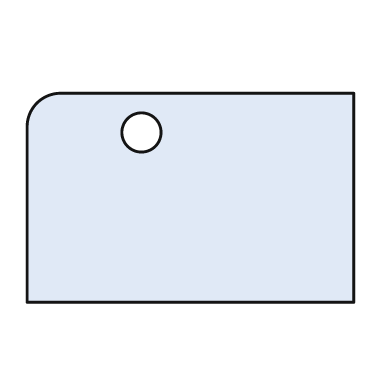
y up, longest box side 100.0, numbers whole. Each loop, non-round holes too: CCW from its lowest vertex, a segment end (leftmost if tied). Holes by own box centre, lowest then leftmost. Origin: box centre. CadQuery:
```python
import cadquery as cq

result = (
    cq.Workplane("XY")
    .moveTo(-50.0, -32.0)
    .lineTo(50.0, -32.0)
    .lineTo(50.0, 32.0)
    .lineTo(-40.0, 32.0)
    .threePointArc((-47.0, 29.0), (-50.0, 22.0))
    .close()
    .moveTo(-15.0, 20.0)
    .circle(6.0)
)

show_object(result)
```